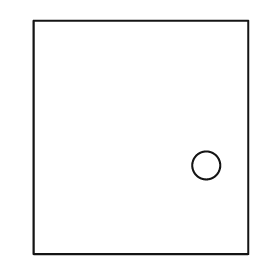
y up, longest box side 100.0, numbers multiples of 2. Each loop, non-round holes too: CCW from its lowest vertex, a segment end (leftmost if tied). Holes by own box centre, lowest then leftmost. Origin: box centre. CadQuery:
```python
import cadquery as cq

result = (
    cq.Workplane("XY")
    .moveTo(-46.0, -50.0)
    .lineTo(46.0, -50.0)
    .lineTo(46.0, 50.0)
    .lineTo(-46.0, 50.0)
    .close()
    .moveTo(28.0, -12.0)
    .circle(6.0)
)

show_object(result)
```